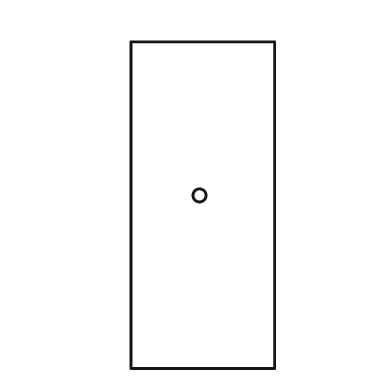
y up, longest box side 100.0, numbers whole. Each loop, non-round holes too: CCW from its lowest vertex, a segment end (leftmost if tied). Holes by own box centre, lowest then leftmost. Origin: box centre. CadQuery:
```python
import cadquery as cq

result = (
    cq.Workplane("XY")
    .moveTo(-22.0, -50.0)
    .lineTo(22.0, -50.0)
    .lineTo(22.0, 50.0)
    .lineTo(-22.0, 50.0)
    .close()
    .moveTo(-1.0, 3.0)
    .circle(2.0)
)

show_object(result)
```